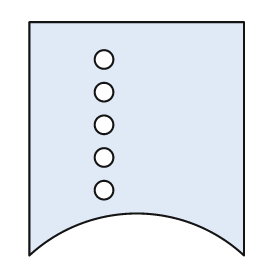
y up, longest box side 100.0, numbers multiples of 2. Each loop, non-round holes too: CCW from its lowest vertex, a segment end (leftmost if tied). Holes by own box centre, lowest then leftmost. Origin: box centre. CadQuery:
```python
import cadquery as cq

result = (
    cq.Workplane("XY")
    .moveTo(-46.0, -50.0)
    .threePointArc((0.0, -32.0), (46.0, -50.0))
    .lineTo(46.0, 50.0)
    .lineTo(-46.0, 50.0)
    .close()
    .moveTo(-14.0, -22.0)
    .circle(4.0)
    .moveTo(-14.0, -8.0)
    .circle(4.0)
    .moveTo(-14.0, 6.0)
    .circle(4.0)
    .moveTo(-14.0, 20.0)
    .circle(4.0)
    .moveTo(-14.0, 34.0)
    .circle(4.0)
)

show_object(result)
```